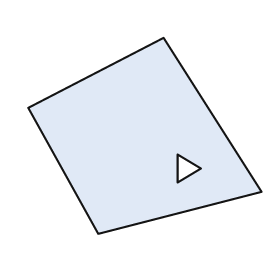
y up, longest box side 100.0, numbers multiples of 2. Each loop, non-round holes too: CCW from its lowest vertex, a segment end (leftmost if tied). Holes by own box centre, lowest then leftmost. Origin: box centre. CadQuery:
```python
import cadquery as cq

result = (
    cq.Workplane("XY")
    .moveTo(-20.0, -42.0)
    .lineTo(50.0, -24.0)
    .lineTo(8.0, 42.0)
    .lineTo(-50.0, 12.0)
    .close()
    .moveTo(14.0, -20.0)
    .lineTo(24.0, -14.0)
    .lineTo(14.0, -8.0)
    .close()
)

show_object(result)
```